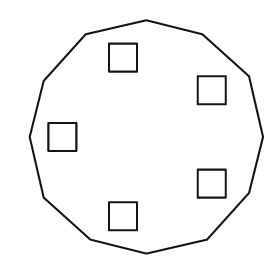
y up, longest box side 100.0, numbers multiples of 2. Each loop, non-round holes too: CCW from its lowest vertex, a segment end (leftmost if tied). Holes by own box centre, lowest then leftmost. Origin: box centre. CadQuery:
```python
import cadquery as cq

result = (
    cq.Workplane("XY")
    .moveTo(0.0, -50.0)
    .lineTo(26.0, -44.0)
    .lineTo(44.0, -24.0)
    .lineTo(50.0, 0.0)
    .lineTo(44.0, 26.0)
    .lineTo(24.0, 44.0)
    .lineTo(0.0, 50.0)
    .lineTo(-26.0, 44.0)
    .lineTo(-44.0, 24.0)
    .lineTo(-50.0, 0.0)
    .lineTo(-44.0, -26.0)
    .lineTo(-24.0, -44.0)
    .close()
    .moveTo(-16.0, -40.0)
    .lineTo(-4.0, -40.0)
    .lineTo(-4.0, -28.0)
    .lineTo(-16.0, -28.0)
    .close()
    .moveTo(22.0, -26.0)
    .lineTo(34.0, -26.0)
    .lineTo(34.0, -14.0)
    .lineTo(22.0, -14.0)
    .close()
    .moveTo(-42.0, -6.0)
    .lineTo(-30.0, -6.0)
    .lineTo(-30.0, 6.0)
    .lineTo(-42.0, 6.0)
    .close()
    .moveTo(22.0, 14.0)
    .lineTo(34.0, 14.0)
    .lineTo(34.0, 26.0)
    .lineTo(22.0, 26.0)
    .close()
    .moveTo(-16.0, 28.0)
    .lineTo(-4.0, 28.0)
    .lineTo(-4.0, 40.0)
    .lineTo(-16.0, 40.0)
    .close()
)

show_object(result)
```